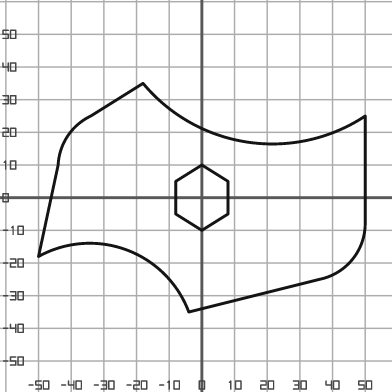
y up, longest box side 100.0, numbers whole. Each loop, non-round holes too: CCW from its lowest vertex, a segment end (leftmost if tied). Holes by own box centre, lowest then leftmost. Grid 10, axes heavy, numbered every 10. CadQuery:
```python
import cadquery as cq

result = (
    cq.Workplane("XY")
    .moveTo(-4.0, -35.0)
    .lineTo(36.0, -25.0)
    .threePointArc((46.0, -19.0), (50.0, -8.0))
    .lineTo(50.0, 25.0)
    .threePointArc((14.0, 17.0), (-18.0, 35.0))
    .lineTo(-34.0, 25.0)
    .threePointArc((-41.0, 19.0), (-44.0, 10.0))
    .lineTo(-50.0, -18.0)
    .threePointArc((-23.0, -16.0), (-4.0, -35.0))
    .close()
    .moveTo(0.0, -10.0)
    .lineTo(8.0, -5.0)
    .lineTo(8.0, 5.0)
    .lineTo(0.0, 10.0)
    .lineTo(-8.0, 5.0)
    .lineTo(-8.0, -5.0)
    .close()
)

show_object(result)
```